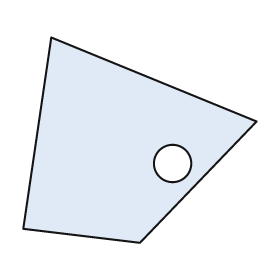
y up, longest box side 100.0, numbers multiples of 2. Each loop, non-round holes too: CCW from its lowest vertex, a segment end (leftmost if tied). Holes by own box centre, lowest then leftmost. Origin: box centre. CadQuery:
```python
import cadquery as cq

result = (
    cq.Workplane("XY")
    .moveTo(0.0, -44.0)
    .lineTo(50.0, 8.0)
    .lineTo(-38.0, 44.0)
    .lineTo(-50.0, -38.0)
    .close()
    .moveTo(14.0, -10.0)
    .circle(8.0)
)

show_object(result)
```